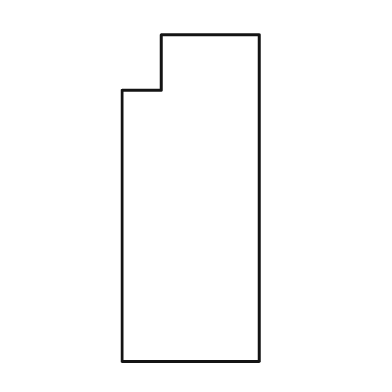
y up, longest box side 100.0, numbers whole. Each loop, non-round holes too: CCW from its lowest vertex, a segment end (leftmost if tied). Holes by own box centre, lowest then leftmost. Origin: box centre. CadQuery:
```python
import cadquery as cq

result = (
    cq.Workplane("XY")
    .moveTo(-21.0, -50.0)
    .lineTo(21.0, -50.0)
    .lineTo(21.0, 50.0)
    .lineTo(-9.0, 50.0)
    .lineTo(-9.0, 33.0)
    .lineTo(-21.0, 33.0)
    .close()
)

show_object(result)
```